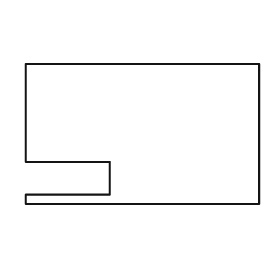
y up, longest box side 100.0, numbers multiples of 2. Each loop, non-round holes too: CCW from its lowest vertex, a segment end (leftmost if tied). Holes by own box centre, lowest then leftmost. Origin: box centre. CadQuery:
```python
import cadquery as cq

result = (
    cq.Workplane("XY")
    .moveTo(-50.0, -30.0)
    .lineTo(50.0, -30.0)
    .lineTo(50.0, 30.0)
    .lineTo(-50.0, 30.0)
    .lineTo(-50.0, -12.0)
    .lineTo(-14.0, -12.0)
    .lineTo(-14.0, -26.0)
    .lineTo(-50.0, -26.0)
    .close()
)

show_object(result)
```